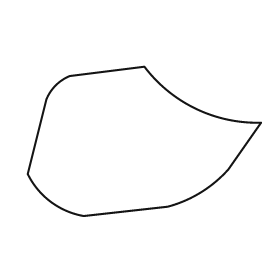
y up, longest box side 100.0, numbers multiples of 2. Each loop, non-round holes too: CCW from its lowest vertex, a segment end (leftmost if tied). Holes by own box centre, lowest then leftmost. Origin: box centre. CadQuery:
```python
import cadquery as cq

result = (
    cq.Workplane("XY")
    .moveTo(-26.0, -32.0)
    .lineTo(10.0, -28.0)
    .threePointArc((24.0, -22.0), (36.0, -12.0))
    .lineTo(50.0, 8.0)
    .threePointArc((22.0, 14.0), (0.0, 32.0))
    .lineTo(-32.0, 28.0)
    .threePointArc((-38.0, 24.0), (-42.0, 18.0))
    .lineTo(-50.0, -14.0)
    .threePointArc((-40.0, -26.0), (-26.0, -32.0))
    .close()
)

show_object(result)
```